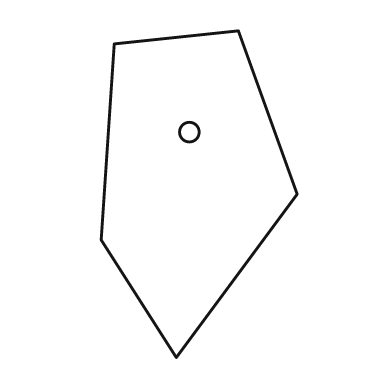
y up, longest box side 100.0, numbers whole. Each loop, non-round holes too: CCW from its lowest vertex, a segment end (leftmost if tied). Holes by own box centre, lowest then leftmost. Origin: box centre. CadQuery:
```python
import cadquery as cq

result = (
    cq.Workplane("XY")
    .moveTo(-7.0, -50.0)
    .lineTo(30.0, 0.0)
    .lineTo(12.0, 50.0)
    .lineTo(-26.0, 46.0)
    .lineTo(-30.0, -14.0)
    .close()
    .moveTo(-3.0, 19.0)
    .circle(3.0)
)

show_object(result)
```